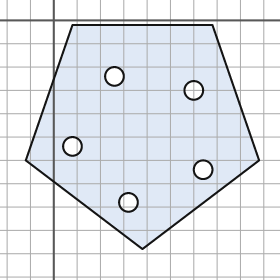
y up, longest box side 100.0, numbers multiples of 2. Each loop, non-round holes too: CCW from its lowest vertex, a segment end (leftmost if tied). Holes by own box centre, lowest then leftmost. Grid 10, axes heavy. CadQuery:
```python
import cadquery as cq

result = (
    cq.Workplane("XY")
    .moveTo(38.0, -98.0)
    .lineTo(88.0, -60.0)
    .lineTo(68.0, -2.0)
    .lineTo(8.0, -2.0)
    .lineTo(-12.0, -60.0)
    .close()
    .moveTo(32.0, -78.0)
    .circle(4.0)
    .moveTo(64.0, -64.0)
    .circle(4.0)
    .moveTo(8.0, -54.0)
    .circle(4.0)
    .moveTo(60.0, -30.0)
    .circle(4.0)
    .moveTo(26.0, -24.0)
    .circle(4.0)
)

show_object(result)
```